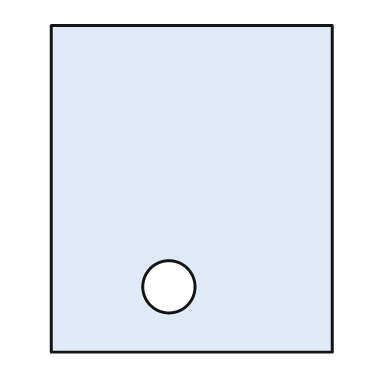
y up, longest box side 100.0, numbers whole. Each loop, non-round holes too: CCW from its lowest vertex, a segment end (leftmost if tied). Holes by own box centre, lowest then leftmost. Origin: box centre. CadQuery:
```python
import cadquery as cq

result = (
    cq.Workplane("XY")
    .moveTo(-43.0, -50.0)
    .lineTo(43.0, -50.0)
    .lineTo(43.0, 50.0)
    .lineTo(-43.0, 50.0)
    .close()
    .moveTo(-7.0, -30.0)
    .circle(8.0)
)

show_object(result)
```